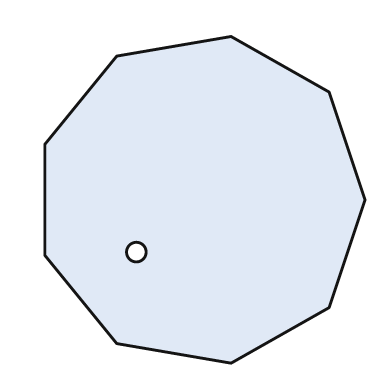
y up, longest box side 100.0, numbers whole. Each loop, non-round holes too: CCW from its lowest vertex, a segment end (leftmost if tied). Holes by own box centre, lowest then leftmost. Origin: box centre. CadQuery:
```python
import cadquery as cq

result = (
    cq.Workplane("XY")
    .moveTo(8.0, -50.0)
    .lineTo(38.0, -33.0)
    .lineTo(49.0, 0.0)
    .lineTo(38.0, 33.0)
    .lineTo(8.0, 50.0)
    .lineTo(-27.0, 44.0)
    .lineTo(-49.0, 17.0)
    .lineTo(-49.0, -17.0)
    .lineTo(-27.0, -44.0)
    .close()
    .moveTo(-21.0, -16.0)
    .circle(3.0)
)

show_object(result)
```